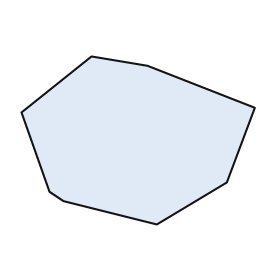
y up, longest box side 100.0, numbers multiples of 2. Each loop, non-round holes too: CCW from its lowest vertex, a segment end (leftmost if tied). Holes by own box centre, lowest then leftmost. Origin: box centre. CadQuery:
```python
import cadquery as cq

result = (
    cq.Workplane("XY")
    .moveTo(8.0, -36.0)
    .lineTo(38.0, -18.0)
    .lineTo(50.0, 14.0)
    .lineTo(4.0, 32.0)
    .lineTo(-20.0, 36.0)
    .lineTo(-50.0, 12.0)
    .lineTo(-38.0, -22.0)
    .lineTo(-32.0, -26.0)
    .close()
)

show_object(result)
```